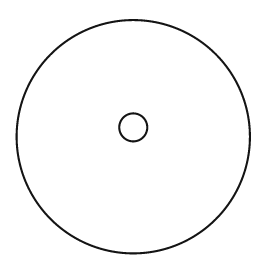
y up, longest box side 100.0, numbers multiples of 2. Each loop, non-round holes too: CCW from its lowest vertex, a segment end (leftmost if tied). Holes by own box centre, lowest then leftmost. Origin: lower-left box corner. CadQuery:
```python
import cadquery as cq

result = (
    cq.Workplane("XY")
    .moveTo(50.0, 50.0)
    .circle(50.0)
    .moveTo(50.0, 54.0)
    .circle(6.0)
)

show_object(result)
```